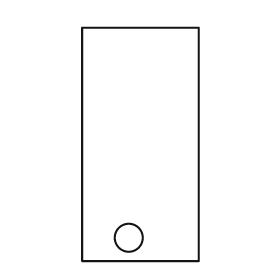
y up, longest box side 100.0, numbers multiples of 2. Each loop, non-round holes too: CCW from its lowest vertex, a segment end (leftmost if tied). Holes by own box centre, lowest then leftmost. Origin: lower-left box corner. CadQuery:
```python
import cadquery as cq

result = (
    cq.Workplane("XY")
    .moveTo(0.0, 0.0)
    .lineTo(50.0, 0.0)
    .lineTo(50.0, 100.0)
    .lineTo(0.0, 100.0)
    .close()
    .moveTo(20.0, 10.0)
    .circle(6.0)
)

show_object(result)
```